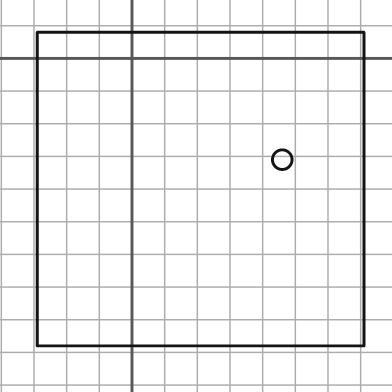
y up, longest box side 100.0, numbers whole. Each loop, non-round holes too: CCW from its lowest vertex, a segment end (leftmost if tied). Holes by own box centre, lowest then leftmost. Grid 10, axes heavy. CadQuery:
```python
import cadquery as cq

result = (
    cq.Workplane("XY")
    .moveTo(-29.0, -88.0)
    .lineTo(71.0, -88.0)
    .lineTo(71.0, 8.0)
    .lineTo(-29.0, 8.0)
    .close()
    .moveTo(46.0, -31.0)
    .circle(3.0)
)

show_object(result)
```